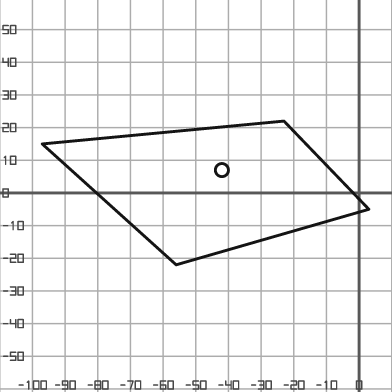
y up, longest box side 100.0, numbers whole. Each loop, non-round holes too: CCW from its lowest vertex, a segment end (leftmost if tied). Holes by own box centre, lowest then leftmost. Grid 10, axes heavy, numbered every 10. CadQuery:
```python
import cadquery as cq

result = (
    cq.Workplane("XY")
    .moveTo(-56.0, -22.0)
    .lineTo(3.0, -5.0)
    .lineTo(-23.0, 22.0)
    .lineTo(-97.0, 15.0)
    .close()
    .moveTo(-42.0, 7.0)
    .circle(2.0)
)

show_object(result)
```